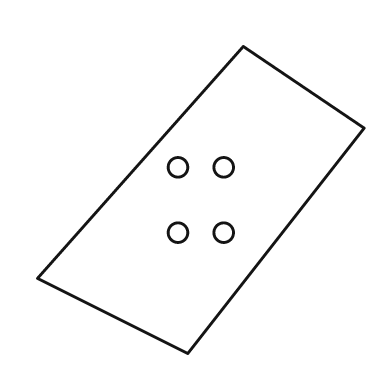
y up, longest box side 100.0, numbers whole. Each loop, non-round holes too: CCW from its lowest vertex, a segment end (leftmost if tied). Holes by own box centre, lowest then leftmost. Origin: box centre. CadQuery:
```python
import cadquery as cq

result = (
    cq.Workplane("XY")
    .moveTo(-4.0, -47.0)
    .lineTo(50.0, 22.0)
    .lineTo(13.0, 47.0)
    .lineTo(-50.0, -24.0)
    .close()
    .moveTo(-7.0, -10.0)
    .circle(3.0)
    .moveTo(7.0, -10.0)
    .circle(3.0)
    .moveTo(-7.0, 10.0)
    .circle(3.0)
    .moveTo(7.0, 10.0)
    .circle(3.0)
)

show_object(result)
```